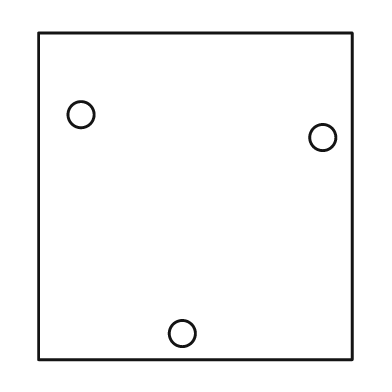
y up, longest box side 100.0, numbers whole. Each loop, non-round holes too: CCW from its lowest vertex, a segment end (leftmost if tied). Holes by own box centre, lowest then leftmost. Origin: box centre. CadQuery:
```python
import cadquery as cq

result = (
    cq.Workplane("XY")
    .moveTo(-48.0, -50.0)
    .lineTo(48.0, -50.0)
    .lineTo(48.0, 50.0)
    .lineTo(-48.0, 50.0)
    .close()
    .moveTo(-4.0, -42.0)
    .circle(4.0)
    .moveTo(39.0, 18.0)
    .circle(4.0)
    .moveTo(-35.0, 25.0)
    .circle(4.0)
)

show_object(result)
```